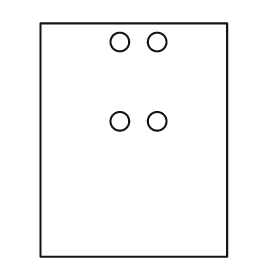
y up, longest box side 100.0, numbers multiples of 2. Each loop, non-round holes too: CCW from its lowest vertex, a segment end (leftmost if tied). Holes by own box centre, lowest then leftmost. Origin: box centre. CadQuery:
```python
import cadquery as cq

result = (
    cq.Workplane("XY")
    .moveTo(-40.0, -50.0)
    .lineTo(40.0, -50.0)
    .lineTo(40.0, 50.0)
    .lineTo(-40.0, 50.0)
    .close()
    .moveTo(-6.0, 8.0)
    .circle(4.0)
    .moveTo(10.0, 8.0)
    .circle(4.0)
    .moveTo(-6.0, 42.0)
    .circle(4.0)
    .moveTo(10.0, 42.0)
    .circle(4.0)
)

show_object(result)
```